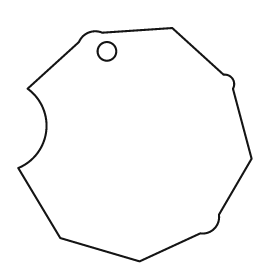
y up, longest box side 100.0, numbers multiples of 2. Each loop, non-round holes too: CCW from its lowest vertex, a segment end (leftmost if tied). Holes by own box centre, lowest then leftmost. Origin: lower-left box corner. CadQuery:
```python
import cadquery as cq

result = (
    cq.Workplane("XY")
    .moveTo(52.0, 0.0)
    .lineTo(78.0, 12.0)
    .threePointArc((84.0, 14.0), (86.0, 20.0))
    .lineTo(100.0, 44.0)
    .lineTo(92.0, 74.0)
    .threePointArc((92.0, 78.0), (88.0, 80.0))
    .lineTo(66.0, 100.0)
    .lineTo(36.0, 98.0)
    .threePointArc((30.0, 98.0), (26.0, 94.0))
    .lineTo(4.0, 74.0)
    .threePointArc((12.0, 56.0), (0.0, 40.0))
    .lineTo(18.0, 10.0)
    .close()
    .moveTo(38.0, 90.0)
    .circle(4.0)
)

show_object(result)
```